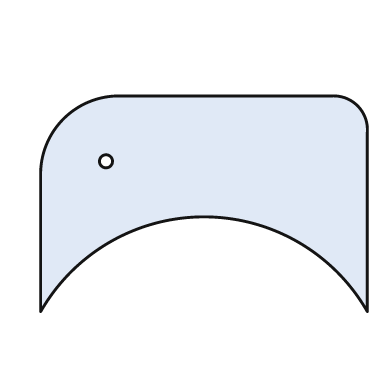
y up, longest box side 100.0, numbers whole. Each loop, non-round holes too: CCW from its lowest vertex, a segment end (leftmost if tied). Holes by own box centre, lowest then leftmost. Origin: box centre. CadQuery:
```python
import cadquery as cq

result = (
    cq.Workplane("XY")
    .moveTo(-50.0, -33.0)
    .threePointArc((0.0, -4.0), (50.0, -33.0))
    .lineTo(50.0, 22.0)
    .threePointArc((47.0, 30.0), (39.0, 33.0))
    .lineTo(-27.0, 33.0)
    .threePointArc((-43.0, 26.0), (-50.0, 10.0))
    .close()
    .moveTo(-30.0, 13.0)
    .circle(2.0)
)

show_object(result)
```